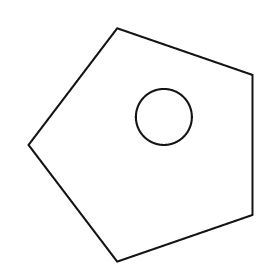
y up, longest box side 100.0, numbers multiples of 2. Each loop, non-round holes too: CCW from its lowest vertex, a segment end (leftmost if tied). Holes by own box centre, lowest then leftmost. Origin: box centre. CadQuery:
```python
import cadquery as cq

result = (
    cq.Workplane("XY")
    .moveTo(-10.0, -50.0)
    .lineTo(48.0, -30.0)
    .lineTo(48.0, 30.0)
    .lineTo(-10.0, 50.0)
    .lineTo(-48.0, 0.0)
    .close()
    .moveTo(10.0, 12.0)
    .circle(12.0)
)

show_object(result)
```